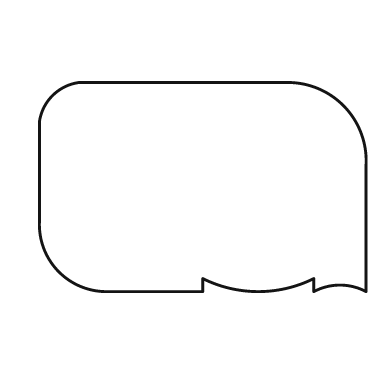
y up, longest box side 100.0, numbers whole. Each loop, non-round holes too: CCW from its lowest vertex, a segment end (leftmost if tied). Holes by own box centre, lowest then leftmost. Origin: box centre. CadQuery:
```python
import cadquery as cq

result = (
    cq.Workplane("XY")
    .moveTo(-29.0, -32.0)
    .lineTo(0.0, -32.0)
    .lineTo(0.0, -28.0)
    .threePointArc((17.0, -32.0), (34.0, -28.0))
    .lineTo(34.0, -32.0)
    .threePointArc((42.0, -30.0), (50.0, -32.0))
    .lineTo(50.0, 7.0)
    .threePointArc((43.0, 25.0), (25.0, 32.0))
    .lineTo(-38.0, 32.0)
    .threePointArc((-46.0, 28.0), (-50.0, 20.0))
    .lineTo(-50.0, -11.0)
    .threePointArc((-44.0, -26.0), (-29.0, -32.0))
    .close()
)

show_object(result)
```